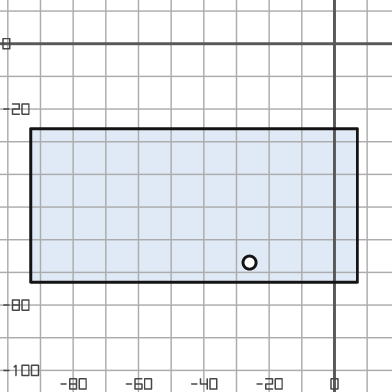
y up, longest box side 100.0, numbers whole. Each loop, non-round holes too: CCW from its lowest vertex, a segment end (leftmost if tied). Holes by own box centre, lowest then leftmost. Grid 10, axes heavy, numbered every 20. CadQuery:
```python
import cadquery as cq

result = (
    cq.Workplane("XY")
    .moveTo(-93.0, -73.0)
    .lineTo(7.0, -73.0)
    .lineTo(7.0, -26.0)
    .lineTo(-93.0, -26.0)
    .close()
    .moveTo(-26.0, -67.0)
    .circle(2.0)
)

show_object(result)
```